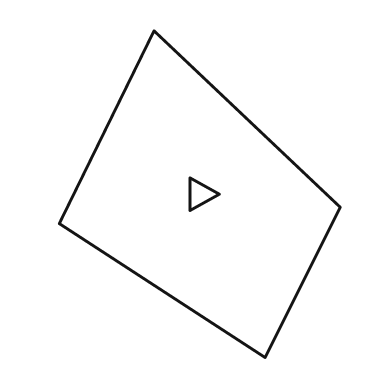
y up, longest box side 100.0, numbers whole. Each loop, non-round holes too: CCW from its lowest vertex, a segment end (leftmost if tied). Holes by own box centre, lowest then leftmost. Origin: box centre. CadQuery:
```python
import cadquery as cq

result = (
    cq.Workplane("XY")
    .moveTo(20.0, -50.0)
    .lineTo(43.0, -4.0)
    .lineTo(-14.0, 50.0)
    .lineTo(-43.0, -9.0)
    .close()
    .moveTo(-3.0, -5.0)
    .lineTo(6.0, 0.0)
    .lineTo(-3.0, 5.0)
    .close()
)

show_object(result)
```